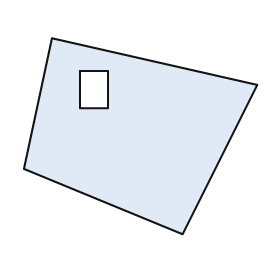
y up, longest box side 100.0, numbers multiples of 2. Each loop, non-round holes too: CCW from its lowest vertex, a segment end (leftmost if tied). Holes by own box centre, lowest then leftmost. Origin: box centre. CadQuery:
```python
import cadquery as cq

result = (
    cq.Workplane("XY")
    .moveTo(18.0, -42.0)
    .lineTo(50.0, 22.0)
    .lineTo(-38.0, 42.0)
    .lineTo(-50.0, -14.0)
    .close()
    .moveTo(-26.0, 12.0)
    .lineTo(-14.0, 12.0)
    .lineTo(-14.0, 28.0)
    .lineTo(-26.0, 28.0)
    .close()
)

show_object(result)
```